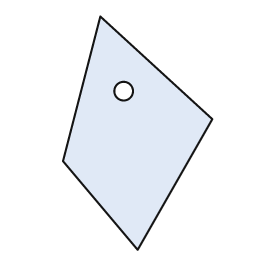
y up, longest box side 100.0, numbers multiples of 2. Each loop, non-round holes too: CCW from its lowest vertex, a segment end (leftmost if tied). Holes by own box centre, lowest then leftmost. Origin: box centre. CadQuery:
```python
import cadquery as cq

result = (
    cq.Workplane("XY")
    .moveTo(0.0, -50.0)
    .lineTo(32.0, 6.0)
    .lineTo(-16.0, 50.0)
    .lineTo(-32.0, -12.0)
    .close()
    .moveTo(-6.0, 18.0)
    .circle(4.0)
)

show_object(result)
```